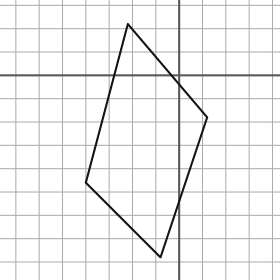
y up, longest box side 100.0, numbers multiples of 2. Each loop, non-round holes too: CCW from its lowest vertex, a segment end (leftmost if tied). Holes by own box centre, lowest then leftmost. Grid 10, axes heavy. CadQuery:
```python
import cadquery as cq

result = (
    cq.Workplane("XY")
    .moveTo(-8.0, -78.0)
    .lineTo(12.0, -18.0)
    .lineTo(-22.0, 22.0)
    .lineTo(-40.0, -46.0)
    .close()
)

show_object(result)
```